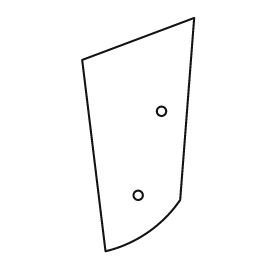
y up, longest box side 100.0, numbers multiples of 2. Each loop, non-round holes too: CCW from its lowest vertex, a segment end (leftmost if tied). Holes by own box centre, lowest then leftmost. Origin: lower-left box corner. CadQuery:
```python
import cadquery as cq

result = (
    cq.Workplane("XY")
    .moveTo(10.0, 0.0)
    .threePointArc((28.0, 8.0), (42.0, 22.0))
    .lineTo(48.0, 100.0)
    .lineTo(0.0, 82.0)
    .close()
    .moveTo(24.0, 24.0)
    .circle(2.0)
    .moveTo(34.0, 60.0)
    .circle(2.0)
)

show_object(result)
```